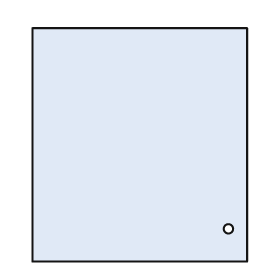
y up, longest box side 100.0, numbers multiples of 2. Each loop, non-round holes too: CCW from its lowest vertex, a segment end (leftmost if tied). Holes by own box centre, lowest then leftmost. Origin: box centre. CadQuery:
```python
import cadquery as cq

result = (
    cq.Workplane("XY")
    .moveTo(-46.0, -50.0)
    .lineTo(46.0, -50.0)
    .lineTo(46.0, 50.0)
    .lineTo(-46.0, 50.0)
    .close()
    .moveTo(38.0, -36.0)
    .circle(2.0)
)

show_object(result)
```